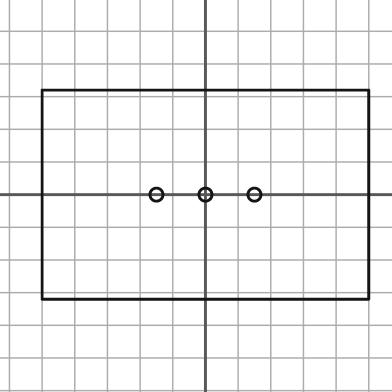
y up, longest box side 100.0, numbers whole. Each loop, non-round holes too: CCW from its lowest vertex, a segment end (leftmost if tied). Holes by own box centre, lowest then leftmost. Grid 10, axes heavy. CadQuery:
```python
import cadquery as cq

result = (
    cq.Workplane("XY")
    .moveTo(-50.0, -32.0)
    .lineTo(50.0, -32.0)
    .lineTo(50.0, 32.0)
    .lineTo(-50.0, 32.0)
    .close()
    .moveTo(-15.0, 0.0)
    .circle(2.0)
    .moveTo(0.0, 0.0)
    .circle(2.0)
    .moveTo(15.0, 0.0)
    .circle(2.0)
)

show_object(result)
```